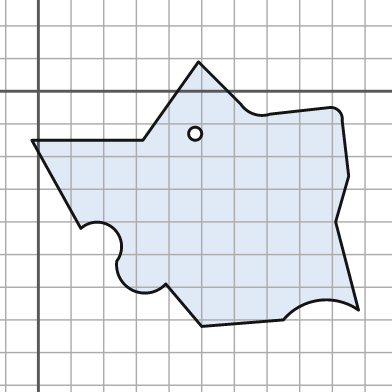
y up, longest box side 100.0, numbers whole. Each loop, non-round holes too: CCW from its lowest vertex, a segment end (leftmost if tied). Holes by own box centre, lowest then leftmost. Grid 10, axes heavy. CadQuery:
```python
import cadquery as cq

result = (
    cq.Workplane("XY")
    .moveTo(50.0, -72.0)
    .lineTo(75.0, -70.0)
    .threePointArc((86.0, -64.0), (98.0, -67.0))
    .lineTo(91.0, -40.0)
    .lineTo(95.0, -26.0)
    .lineTo(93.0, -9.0)
    .threePointArc((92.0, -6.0), (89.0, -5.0))
    .lineTo(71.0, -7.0)
    .threePointArc((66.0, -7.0), (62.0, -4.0))
    .lineTo(49.0, 9.0)
    .lineTo(32.0, -15.0)
    .lineTo(-2.0, -15.0)
    .lineTo(13.0, -42.0)
    .threePointArc((23.0, -42.0), (24.0, -52.0))
    .threePointArc((29.0, -61.0), (39.0, -59.0))
    .close()
    .moveTo(48.0, -13.0)
    .circle(2.0)
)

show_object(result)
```